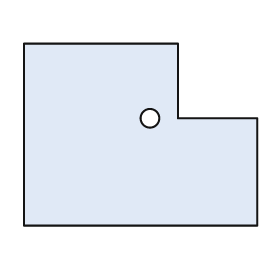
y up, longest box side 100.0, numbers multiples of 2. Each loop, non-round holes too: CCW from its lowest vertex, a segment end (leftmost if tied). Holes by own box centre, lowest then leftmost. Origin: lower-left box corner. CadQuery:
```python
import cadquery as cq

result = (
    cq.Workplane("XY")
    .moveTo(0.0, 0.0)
    .lineTo(100.0, 0.0)
    .lineTo(100.0, 46.0)
    .lineTo(66.0, 46.0)
    .lineTo(66.0, 78.0)
    .lineTo(0.0, 78.0)
    .close()
    .moveTo(54.0, 46.0)
    .circle(4.0)
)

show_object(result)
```